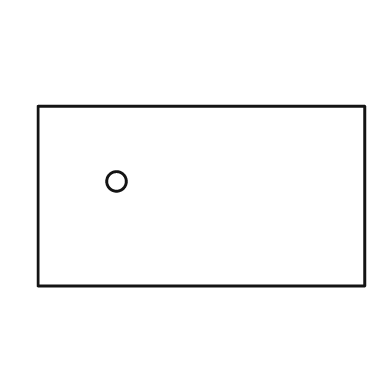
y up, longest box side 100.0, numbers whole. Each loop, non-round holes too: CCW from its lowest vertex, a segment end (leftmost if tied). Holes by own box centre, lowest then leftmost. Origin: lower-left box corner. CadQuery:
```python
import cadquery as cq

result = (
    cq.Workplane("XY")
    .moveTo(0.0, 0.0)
    .lineTo(100.0, 0.0)
    .lineTo(100.0, 55.0)
    .lineTo(0.0, 55.0)
    .close()
    .moveTo(24.0, 32.0)
    .circle(3.0)
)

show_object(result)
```